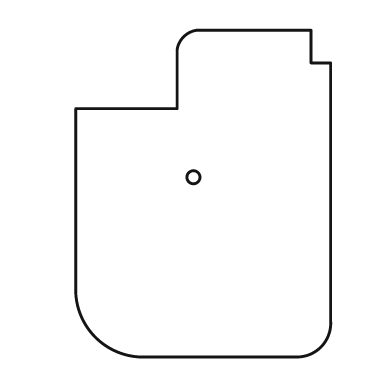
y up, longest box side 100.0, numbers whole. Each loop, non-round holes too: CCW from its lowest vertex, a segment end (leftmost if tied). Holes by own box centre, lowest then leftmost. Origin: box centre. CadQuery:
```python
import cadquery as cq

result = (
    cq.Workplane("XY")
    .moveTo(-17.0, -50.0)
    .lineTo(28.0, -50.0)
    .threePointArc((36.0, -47.0), (39.0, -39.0))
    .lineTo(39.0, 40.0)
    .lineTo(33.0, 40.0)
    .lineTo(33.0, 50.0)
    .lineTo(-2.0, 50.0)
    .threePointArc((-6.0, 48.0), (-8.0, 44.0))
    .lineTo(-8.0, 26.0)
    .lineTo(-39.0, 26.0)
    .lineTo(-39.0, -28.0)
    .threePointArc((-33.0, -44.0), (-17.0, -50.0))
    .close()
    .moveTo(-3.0, 5.0)
    .circle(2.0)
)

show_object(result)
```